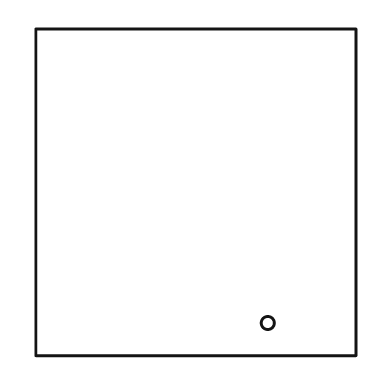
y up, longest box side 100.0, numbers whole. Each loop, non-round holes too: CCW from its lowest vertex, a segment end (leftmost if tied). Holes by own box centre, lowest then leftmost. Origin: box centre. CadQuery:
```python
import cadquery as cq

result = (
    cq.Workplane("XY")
    .moveTo(-49.0, -50.0)
    .lineTo(49.0, -50.0)
    .lineTo(49.0, 50.0)
    .lineTo(-49.0, 50.0)
    .close()
    .moveTo(22.0, -40.0)
    .circle(2.0)
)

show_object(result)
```